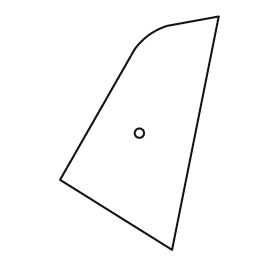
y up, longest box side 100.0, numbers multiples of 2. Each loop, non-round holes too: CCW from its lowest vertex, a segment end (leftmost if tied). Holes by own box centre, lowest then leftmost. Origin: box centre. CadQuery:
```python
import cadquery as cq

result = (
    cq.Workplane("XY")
    .moveTo(14.0, -50.0)
    .lineTo(34.0, 50.0)
    .lineTo(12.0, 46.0)
    .threePointArc((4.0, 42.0), (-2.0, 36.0))
    .lineTo(-34.0, -20.0)
    .close()
    .moveTo(0.0, 0.0)
    .circle(2.0)
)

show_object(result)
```